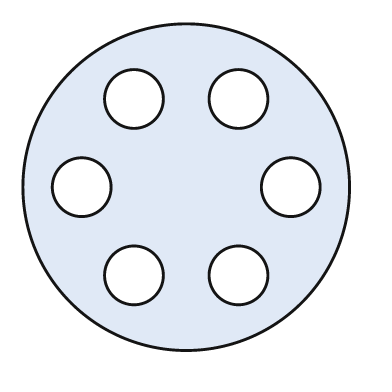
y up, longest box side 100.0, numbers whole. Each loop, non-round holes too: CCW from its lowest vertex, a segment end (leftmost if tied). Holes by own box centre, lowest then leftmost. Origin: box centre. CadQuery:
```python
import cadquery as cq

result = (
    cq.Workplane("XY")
    .moveTo(0.0, 0.0)
    .circle(50.0)
    .moveTo(-16.0, -27.0)
    .circle(9.0)
    .moveTo(16.0, -27.0)
    .circle(9.0)
    .moveTo(-32.0, 0.0)
    .circle(9.0)
    .moveTo(32.0, 0.0)
    .circle(9.0)
    .moveTo(-16.0, 27.0)
    .circle(9.0)
    .moveTo(16.0, 27.0)
    .circle(9.0)
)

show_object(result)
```